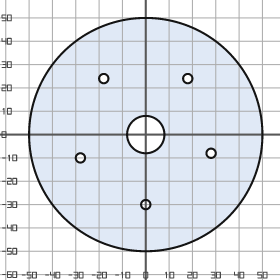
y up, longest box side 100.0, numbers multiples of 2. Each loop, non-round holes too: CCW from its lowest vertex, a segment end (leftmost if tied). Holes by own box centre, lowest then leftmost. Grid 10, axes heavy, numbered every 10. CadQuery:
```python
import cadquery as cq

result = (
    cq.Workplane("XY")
    .moveTo(0.0, 0.0)
    .circle(50.0)
    .moveTo(0.0, -30.0)
    .circle(2.0)
    .moveTo(-28.0, -10.0)
    .circle(2.0)
    .moveTo(28.0, -8.0)
    .circle(2.0)
    .moveTo(0.0, 0.0)
    .circle(8.0)
    .moveTo(-18.0, 24.0)
    .circle(2.0)
    .moveTo(18.0, 24.0)
    .circle(2.0)
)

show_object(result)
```